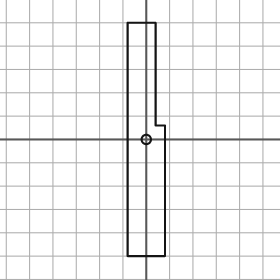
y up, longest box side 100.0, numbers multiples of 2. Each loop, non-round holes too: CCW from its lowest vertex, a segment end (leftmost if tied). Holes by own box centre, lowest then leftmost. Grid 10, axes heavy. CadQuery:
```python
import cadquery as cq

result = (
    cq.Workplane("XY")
    .moveTo(-8.0, -50.0)
    .lineTo(8.0, -50.0)
    .lineTo(8.0, 6.0)
    .lineTo(4.0, 6.0)
    .lineTo(4.0, 50.0)
    .lineTo(-8.0, 50.0)
    .close()
    .moveTo(0.0, 0.0)
    .circle(2.0)
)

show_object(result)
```